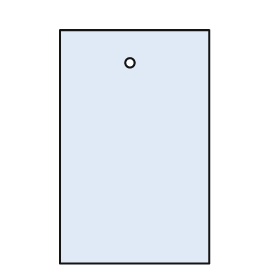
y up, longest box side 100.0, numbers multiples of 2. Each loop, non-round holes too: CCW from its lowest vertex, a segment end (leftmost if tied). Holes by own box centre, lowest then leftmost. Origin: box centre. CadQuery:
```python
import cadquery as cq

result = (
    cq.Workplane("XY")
    .moveTo(-32.0, -50.0)
    .lineTo(32.0, -50.0)
    .lineTo(32.0, 50.0)
    .lineTo(-32.0, 50.0)
    .close()
    .moveTo(-2.0, 36.0)
    .circle(2.0)
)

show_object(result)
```